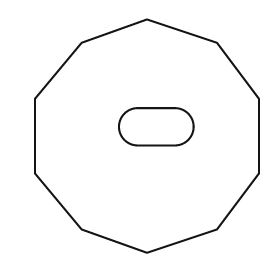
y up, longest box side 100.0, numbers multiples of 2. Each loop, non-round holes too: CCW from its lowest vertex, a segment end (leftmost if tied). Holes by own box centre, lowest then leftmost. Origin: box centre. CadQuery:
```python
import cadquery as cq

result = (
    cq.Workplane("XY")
    .moveTo(0.0, -50.0)
    .lineTo(30.0, -40.0)
    .lineTo(48.0, -16.0)
    .lineTo(48.0, 16.0)
    .lineTo(30.0, 40.0)
    .lineTo(0.0, 50.0)
    .lineTo(-28.0, 40.0)
    .lineTo(-48.0, 16.0)
    .lineTo(-48.0, -16.0)
    .lineTo(-28.0, -40.0)
    .close()
    .moveTo(-4.0, -4.0)
    .lineTo(12.0, -4.0)
    .threePointArc((20.0, 4.0), (12.0, 12.0))
    .lineTo(-4.0, 12.0)
    .threePointArc((-12.0, 4.0), (-4.0, -4.0))
    .close()
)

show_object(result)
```